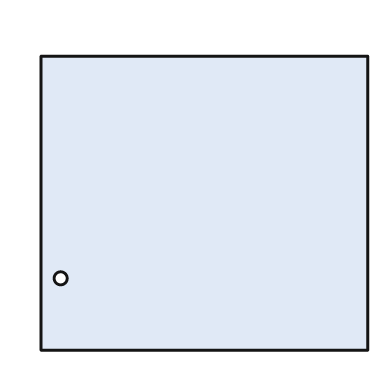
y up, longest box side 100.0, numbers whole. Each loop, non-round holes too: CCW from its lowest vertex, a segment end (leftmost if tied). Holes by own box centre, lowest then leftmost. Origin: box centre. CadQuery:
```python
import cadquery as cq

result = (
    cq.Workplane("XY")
    .moveTo(-50.0, -45.0)
    .lineTo(50.0, -45.0)
    .lineTo(50.0, 45.0)
    .lineTo(-50.0, 45.0)
    .close()
    .moveTo(-44.0, -23.0)
    .circle(2.0)
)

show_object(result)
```